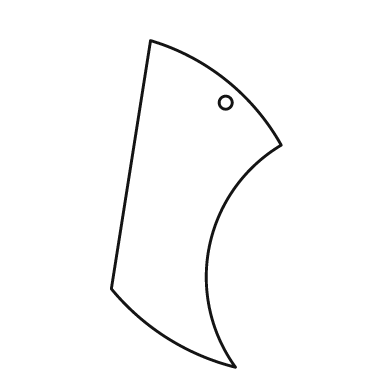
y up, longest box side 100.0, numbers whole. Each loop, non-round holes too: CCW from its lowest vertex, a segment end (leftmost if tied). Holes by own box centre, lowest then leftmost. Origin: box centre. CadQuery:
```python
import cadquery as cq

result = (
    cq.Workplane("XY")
    .moveTo(12.0, -50.0)
    .threePointArc((4.0, -13.0), (26.0, 18.0))
    .threePointArc((9.0, 38.0), (-14.0, 50.0))
    .lineTo(-26.0, -26.0)
    .threePointArc((-9.0, -41.0), (12.0, -50.0))
    .close()
    .moveTo(9.0, 31.0)
    .circle(2.0)
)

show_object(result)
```